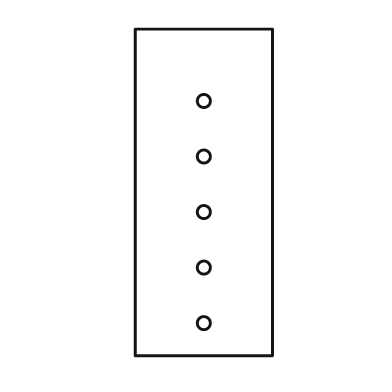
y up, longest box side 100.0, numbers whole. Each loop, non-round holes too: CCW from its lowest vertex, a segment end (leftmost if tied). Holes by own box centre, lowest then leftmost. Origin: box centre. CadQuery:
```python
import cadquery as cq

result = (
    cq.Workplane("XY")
    .moveTo(-21.0, -50.0)
    .lineTo(21.0, -50.0)
    .lineTo(21.0, 50.0)
    .lineTo(-21.0, 50.0)
    .close()
    .moveTo(0.0, -40.0)
    .circle(2.0)
    .moveTo(0.0, -23.0)
    .circle(2.0)
    .moveTo(0.0, -6.0)
    .circle(2.0)
    .moveTo(0.0, 11.0)
    .circle(2.0)
    .moveTo(0.0, 28.0)
    .circle(2.0)
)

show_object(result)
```